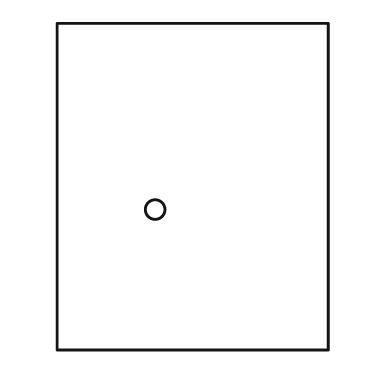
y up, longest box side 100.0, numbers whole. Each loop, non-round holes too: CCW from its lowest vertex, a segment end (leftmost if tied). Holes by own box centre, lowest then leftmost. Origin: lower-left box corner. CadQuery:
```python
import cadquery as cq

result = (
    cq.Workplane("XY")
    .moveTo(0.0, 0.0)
    .lineTo(83.0, 0.0)
    .lineTo(83.0, 100.0)
    .lineTo(0.0, 100.0)
    .close()
    .moveTo(30.0, 43.0)
    .circle(3.0)
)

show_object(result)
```